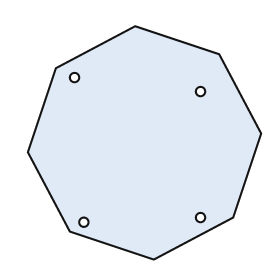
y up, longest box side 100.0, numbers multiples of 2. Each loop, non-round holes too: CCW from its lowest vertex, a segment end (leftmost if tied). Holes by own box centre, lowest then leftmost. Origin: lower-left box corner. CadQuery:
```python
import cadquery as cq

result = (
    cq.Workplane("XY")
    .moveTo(54.0, 0.0)
    .lineTo(88.0, 18.0)
    .lineTo(100.0, 54.0)
    .lineTo(82.0, 88.0)
    .lineTo(46.0, 100.0)
    .lineTo(12.0, 82.0)
    .lineTo(0.0, 46.0)
    .lineTo(18.0, 12.0)
    .close()
    .moveTo(24.0, 16.0)
    .circle(2.0)
    .moveTo(74.0, 18.0)
    .circle(2.0)
    .moveTo(74.0, 72.0)
    .circle(2.0)
    .moveTo(20.0, 78.0)
    .circle(2.0)
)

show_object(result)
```